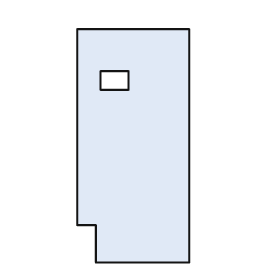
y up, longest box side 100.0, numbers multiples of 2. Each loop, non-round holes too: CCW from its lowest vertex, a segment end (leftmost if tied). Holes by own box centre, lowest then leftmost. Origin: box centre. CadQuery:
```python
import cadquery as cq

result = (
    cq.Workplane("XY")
    .moveTo(-16.0, -50.0)
    .lineTo(24.0, -50.0)
    .lineTo(24.0, 50.0)
    .lineTo(-24.0, 50.0)
    .lineTo(-24.0, -34.0)
    .lineTo(-16.0, -34.0)
    .close()
    .moveTo(-14.0, 24.0)
    .lineTo(-2.0, 24.0)
    .lineTo(-2.0, 32.0)
    .lineTo(-14.0, 32.0)
    .close()
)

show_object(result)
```